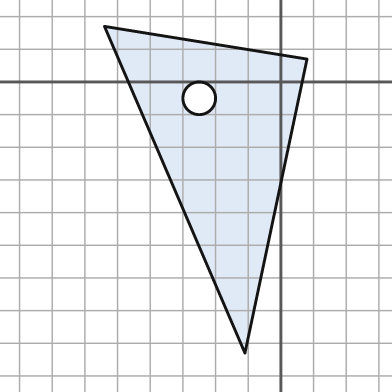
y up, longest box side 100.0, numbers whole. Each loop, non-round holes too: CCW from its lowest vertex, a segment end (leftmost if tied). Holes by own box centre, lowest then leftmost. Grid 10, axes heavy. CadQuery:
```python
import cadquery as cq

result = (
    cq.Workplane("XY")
    .moveTo(-11.0, -83.0)
    .lineTo(8.0, 7.0)
    .lineTo(-54.0, 17.0)
    .close()
    .moveTo(-25.0, -5.0)
    .circle(5.0)
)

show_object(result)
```